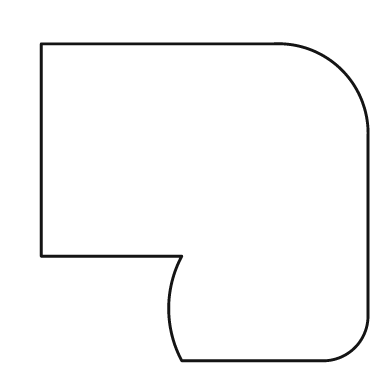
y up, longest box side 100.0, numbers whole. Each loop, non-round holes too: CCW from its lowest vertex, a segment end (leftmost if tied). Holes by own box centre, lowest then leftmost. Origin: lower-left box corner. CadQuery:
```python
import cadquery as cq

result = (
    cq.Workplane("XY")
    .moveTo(43.0, 0.0)
    .lineTo(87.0, 0.0)
    .threePointArc((96.0, 4.0), (100.0, 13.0))
    .lineTo(100.0, 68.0)
    .threePointArc((92.0, 89.0), (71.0, 97.0))
    .lineTo(0.0, 97.0)
    .lineTo(0.0, 32.0)
    .lineTo(43.0, 32.0)
    .threePointArc((39.0, 16.0), (43.0, 0.0))
    .close()
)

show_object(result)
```